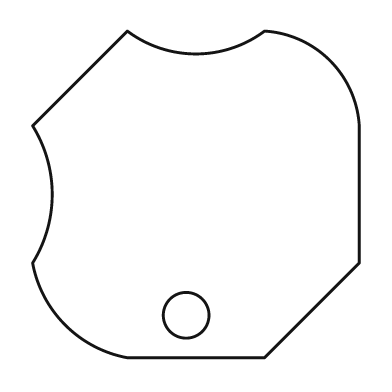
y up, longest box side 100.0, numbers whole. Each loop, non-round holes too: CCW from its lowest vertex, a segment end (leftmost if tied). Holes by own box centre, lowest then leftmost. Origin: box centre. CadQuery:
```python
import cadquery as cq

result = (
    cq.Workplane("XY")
    .moveTo(-21.0, -50.0)
    .lineTo(21.0, -50.0)
    .lineTo(50.0, -21.0)
    .lineTo(50.0, 21.0)
    .threePointArc((41.0, 41.0), (21.0, 50.0))
    .threePointArc((0.0, 43.0), (-21.0, 50.0))
    .lineTo(-50.0, 21.0)
    .threePointArc((-44.0, 0.0), (-50.0, -21.0))
    .threePointArc((-40.0, -40.0), (-21.0, -50.0))
    .close()
    .moveTo(-3.0, -37.0)
    .circle(7.0)
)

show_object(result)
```